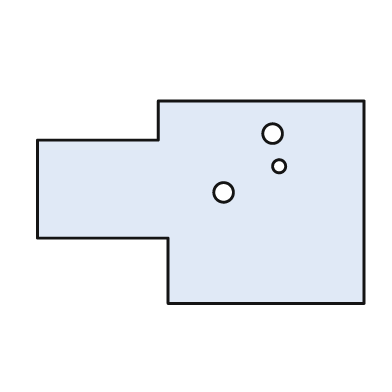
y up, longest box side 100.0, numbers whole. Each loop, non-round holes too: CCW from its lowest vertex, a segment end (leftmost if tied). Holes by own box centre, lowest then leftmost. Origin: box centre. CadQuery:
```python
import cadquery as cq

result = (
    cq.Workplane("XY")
    .moveTo(-10.0, -31.0)
    .lineTo(50.0, -31.0)
    .lineTo(50.0, 31.0)
    .lineTo(-13.0, 31.0)
    .lineTo(-13.0, 19.0)
    .lineTo(-50.0, 19.0)
    .lineTo(-50.0, -11.0)
    .lineTo(-10.0, -11.0)
    .close()
    .moveTo(7.0, 3.0)
    .circle(3.0)
    .moveTo(24.0, 11.0)
    .circle(2.0)
    .moveTo(22.0, 21.0)
    .circle(3.0)
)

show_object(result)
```